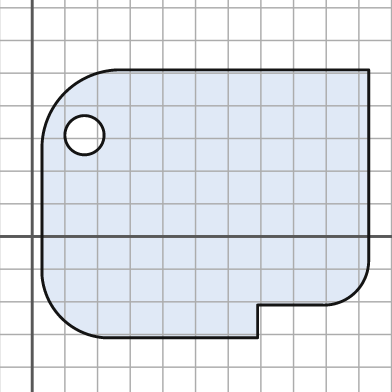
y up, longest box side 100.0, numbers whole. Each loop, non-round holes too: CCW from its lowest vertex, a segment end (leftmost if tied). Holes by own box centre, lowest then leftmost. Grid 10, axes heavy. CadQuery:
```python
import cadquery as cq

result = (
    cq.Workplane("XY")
    .moveTo(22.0, -31.0)
    .lineTo(69.0, -31.0)
    .lineTo(69.0, -21.0)
    .lineTo(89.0, -21.0)
    .threePointArc((99.0, -17.0), (103.0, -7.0))
    .lineTo(103.0, 51.0)
    .lineTo(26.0, 51.0)
    .threePointArc((10.0, 44.0), (3.0, 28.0))
    .lineTo(3.0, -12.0)
    .threePointArc((9.0, -25.0), (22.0, -31.0))
    .close()
    .moveTo(16.0, 31.0)
    .circle(6.0)
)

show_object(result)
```